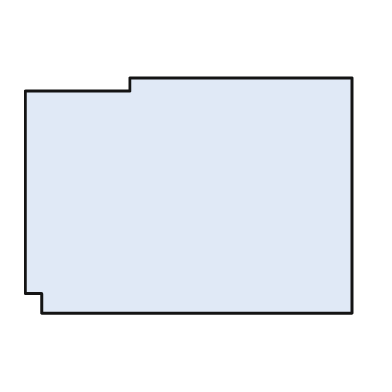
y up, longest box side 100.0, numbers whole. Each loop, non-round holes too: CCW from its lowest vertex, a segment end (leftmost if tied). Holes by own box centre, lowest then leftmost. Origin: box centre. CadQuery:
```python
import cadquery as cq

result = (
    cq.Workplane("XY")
    .moveTo(-45.0, -36.0)
    .lineTo(50.0, -36.0)
    .lineTo(50.0, 36.0)
    .lineTo(-18.0, 36.0)
    .lineTo(-18.0, 32.0)
    .lineTo(-50.0, 32.0)
    .lineTo(-50.0, -30.0)
    .lineTo(-45.0, -30.0)
    .close()
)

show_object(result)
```